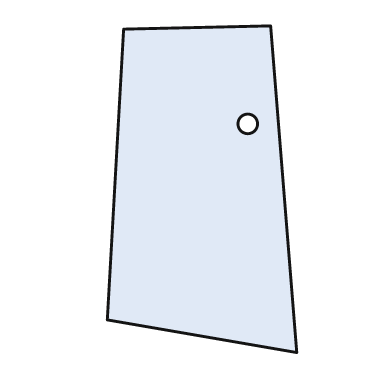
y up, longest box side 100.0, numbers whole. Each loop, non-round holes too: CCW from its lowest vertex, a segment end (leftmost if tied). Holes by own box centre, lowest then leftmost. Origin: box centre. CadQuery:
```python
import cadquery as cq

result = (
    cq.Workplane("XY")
    .moveTo(29.0, -50.0)
    .lineTo(21.0, 50.0)
    .lineTo(-24.0, 49.0)
    .lineTo(-29.0, -40.0)
    .close()
    .moveTo(14.0, 20.0)
    .circle(3.0)
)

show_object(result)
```